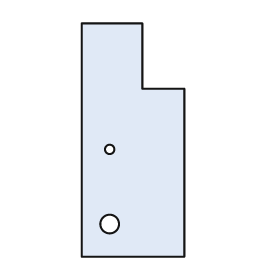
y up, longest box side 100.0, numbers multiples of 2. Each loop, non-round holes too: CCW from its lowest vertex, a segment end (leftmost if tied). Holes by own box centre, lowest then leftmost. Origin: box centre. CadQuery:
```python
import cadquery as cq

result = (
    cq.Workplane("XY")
    .moveTo(-22.0, -50.0)
    .lineTo(22.0, -50.0)
    .lineTo(22.0, 22.0)
    .lineTo(4.0, 22.0)
    .lineTo(4.0, 50.0)
    .lineTo(-22.0, 50.0)
    .close()
    .moveTo(-10.0, -36.0)
    .circle(4.0)
    .moveTo(-10.0, -4.0)
    .circle(2.0)
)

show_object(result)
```